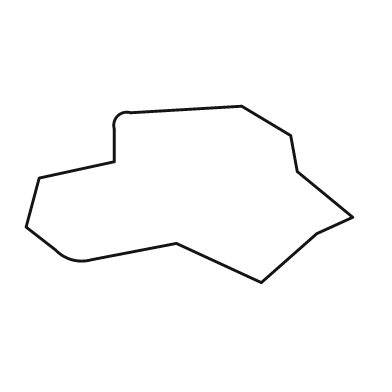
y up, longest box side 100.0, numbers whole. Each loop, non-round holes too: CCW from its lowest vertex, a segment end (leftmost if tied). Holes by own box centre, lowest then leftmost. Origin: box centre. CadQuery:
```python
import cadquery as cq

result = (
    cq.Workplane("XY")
    .moveTo(22.0, -27.0)
    .lineTo(39.0, -12.0)
    .lineTo(50.0, -7.0)
    .lineTo(33.0, 7.0)
    .lineTo(31.0, 18.0)
    .lineTo(16.0, 27.0)
    .lineTo(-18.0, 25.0)
    .threePointArc((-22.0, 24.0), (-23.0, 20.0))
    .lineTo(-23.0, 10.0)
    .lineTo(-46.0, 5.0)
    .lineTo(-50.0, -10.0)
    .lineTo(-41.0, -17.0)
    .threePointArc((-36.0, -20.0), (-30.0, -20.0))
    .lineTo(-4.0, -15.0)
    .close()
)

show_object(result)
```